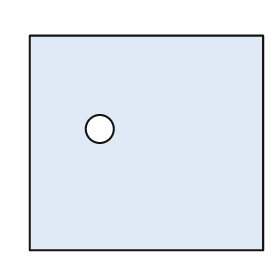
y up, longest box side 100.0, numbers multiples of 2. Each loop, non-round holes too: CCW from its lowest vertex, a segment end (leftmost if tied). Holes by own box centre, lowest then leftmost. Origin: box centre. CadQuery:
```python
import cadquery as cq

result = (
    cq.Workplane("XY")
    .moveTo(-50.0, -46.0)
    .lineTo(50.0, -46.0)
    .lineTo(50.0, 46.0)
    .lineTo(-50.0, 46.0)
    .close()
    .moveTo(-20.0, 6.0)
    .circle(6.0)
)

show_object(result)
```